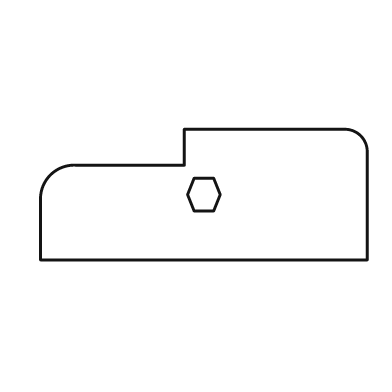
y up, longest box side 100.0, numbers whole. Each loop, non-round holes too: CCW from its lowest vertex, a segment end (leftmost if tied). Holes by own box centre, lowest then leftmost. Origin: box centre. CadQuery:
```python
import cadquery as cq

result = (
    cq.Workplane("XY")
    .moveTo(-50.0, -20.0)
    .lineTo(50.0, -20.0)
    .lineTo(50.0, 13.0)
    .threePointArc((48.0, 18.0), (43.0, 20.0))
    .lineTo(-6.0, 20.0)
    .lineTo(-6.0, 9.0)
    .lineTo(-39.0, 9.0)
    .threePointArc((-47.0, 6.0), (-50.0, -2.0))
    .close()
    .moveTo(-3.0, -5.0)
    .lineTo(3.0, -5.0)
    .lineTo(5.0, 0.0)
    .lineTo(3.0, 5.0)
    .lineTo(-3.0, 5.0)
    .lineTo(-5.0, 0.0)
    .close()
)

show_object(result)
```